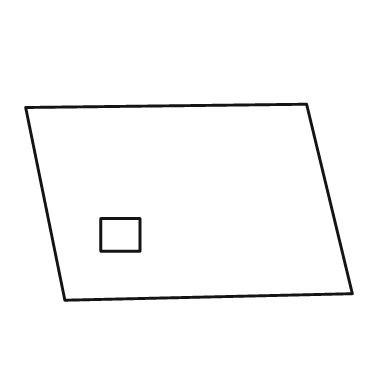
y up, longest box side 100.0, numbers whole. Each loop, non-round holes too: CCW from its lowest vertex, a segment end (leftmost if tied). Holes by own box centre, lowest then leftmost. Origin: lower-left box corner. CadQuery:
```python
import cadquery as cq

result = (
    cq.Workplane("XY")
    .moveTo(12.0, 0.0)
    .lineTo(100.0, 2.0)
    .lineTo(86.0, 60.0)
    .lineTo(0.0, 59.0)
    .close()
    .moveTo(23.0, 15.0)
    .lineTo(35.0, 15.0)
    .lineTo(35.0, 25.0)
    .lineTo(23.0, 25.0)
    .close()
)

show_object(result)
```